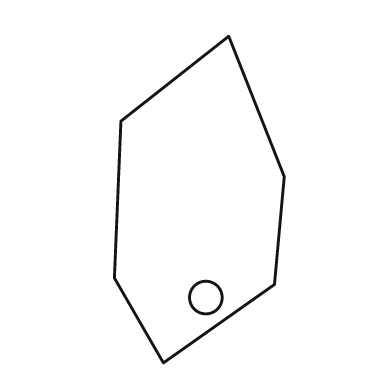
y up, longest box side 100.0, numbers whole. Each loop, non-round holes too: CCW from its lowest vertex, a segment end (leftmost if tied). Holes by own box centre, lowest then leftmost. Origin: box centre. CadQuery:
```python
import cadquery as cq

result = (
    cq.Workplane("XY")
    .moveTo(-11.0, -50.0)
    .lineTo(23.0, -26.0)
    .lineTo(26.0, 7.0)
    .lineTo(9.0, 50.0)
    .lineTo(-24.0, 24.0)
    .lineTo(-26.0, -24.0)
    .close()
    .moveTo(2.0, -30.0)
    .circle(5.0)
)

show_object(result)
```